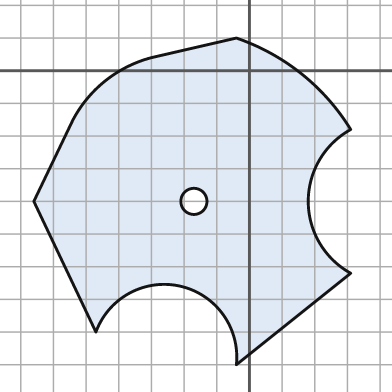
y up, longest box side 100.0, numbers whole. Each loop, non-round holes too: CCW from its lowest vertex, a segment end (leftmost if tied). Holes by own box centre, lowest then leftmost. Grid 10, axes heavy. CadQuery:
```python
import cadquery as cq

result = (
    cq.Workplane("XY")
    .moveTo(-4.0, -90.0)
    .lineTo(31.0, -62.0)
    .threePointArc((18.0, -40.0), (31.0, -18.0))
    .threePointArc((16.0, -1.0), (-4.0, 10.0))
    .lineTo(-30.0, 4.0)
    .threePointArc((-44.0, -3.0), (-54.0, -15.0))
    .lineTo(-66.0, -40.0)
    .lineTo(-47.0, -80.0)
    .threePointArc((-21.0, -66.0), (-4.0, -90.0))
    .close()
    .moveTo(-17.0, -40.0)
    .circle(4.0)
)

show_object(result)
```